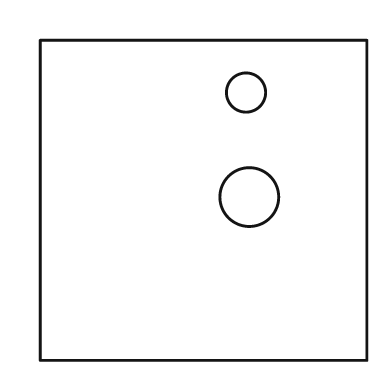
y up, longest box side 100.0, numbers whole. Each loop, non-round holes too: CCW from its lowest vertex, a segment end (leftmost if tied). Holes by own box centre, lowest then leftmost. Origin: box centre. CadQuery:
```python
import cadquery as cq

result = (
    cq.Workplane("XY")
    .moveTo(-50.0, -49.0)
    .lineTo(50.0, -49.0)
    .lineTo(50.0, 49.0)
    .lineTo(-50.0, 49.0)
    .close()
    .moveTo(14.0, 1.0)
    .circle(9.0)
    .moveTo(13.0, 33.0)
    .circle(6.0)
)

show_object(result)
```